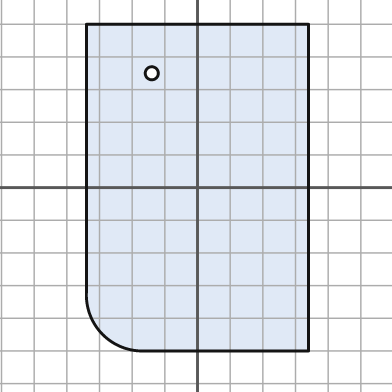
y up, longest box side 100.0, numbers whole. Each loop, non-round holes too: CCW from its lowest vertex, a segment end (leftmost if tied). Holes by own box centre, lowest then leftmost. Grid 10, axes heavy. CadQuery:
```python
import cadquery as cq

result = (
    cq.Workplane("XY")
    .moveTo(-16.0, -50.0)
    .lineTo(34.0, -50.0)
    .lineTo(34.0, 50.0)
    .lineTo(-34.0, 50.0)
    .lineTo(-34.0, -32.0)
    .threePointArc((-29.0, -45.0), (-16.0, -50.0))
    .close()
    .moveTo(-14.0, 35.0)
    .circle(2.0)
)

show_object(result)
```